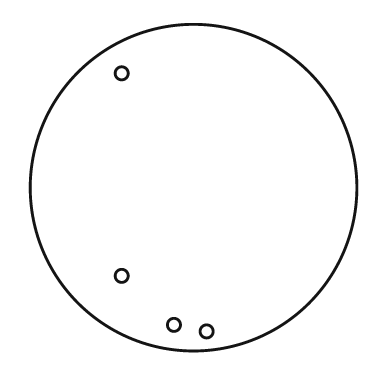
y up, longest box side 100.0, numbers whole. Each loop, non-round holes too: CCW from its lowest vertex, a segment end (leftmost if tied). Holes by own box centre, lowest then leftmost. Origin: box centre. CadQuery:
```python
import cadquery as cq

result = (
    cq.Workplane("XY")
    .moveTo(0.0, 0.0)
    .circle(50.0)
    .moveTo(4.0, -44.0)
    .circle(2.0)
    .moveTo(-6.0, -42.0)
    .circle(2.0)
    .moveTo(-22.0, -27.0)
    .circle(2.0)
    .moveTo(-22.0, 35.0)
    .circle(2.0)
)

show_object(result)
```